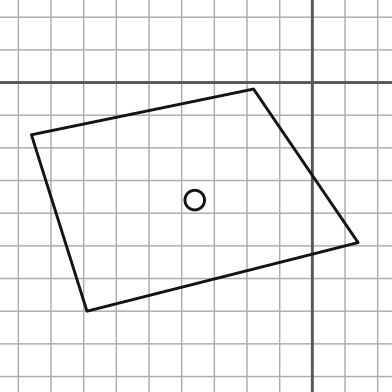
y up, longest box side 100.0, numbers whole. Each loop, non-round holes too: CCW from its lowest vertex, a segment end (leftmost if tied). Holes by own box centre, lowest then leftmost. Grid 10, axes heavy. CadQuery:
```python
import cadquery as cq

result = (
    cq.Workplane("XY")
    .moveTo(-69.0, -70.0)
    .lineTo(14.0, -49.0)
    .lineTo(-18.0, -2.0)
    .lineTo(-86.0, -16.0)
    .close()
    .moveTo(-36.0, -36.0)
    .circle(3.0)
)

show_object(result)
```